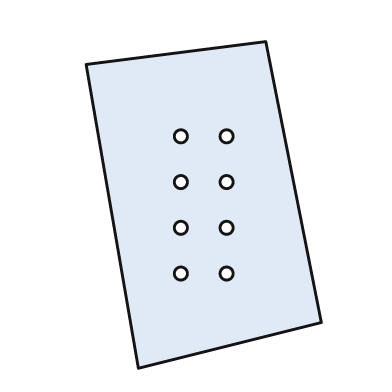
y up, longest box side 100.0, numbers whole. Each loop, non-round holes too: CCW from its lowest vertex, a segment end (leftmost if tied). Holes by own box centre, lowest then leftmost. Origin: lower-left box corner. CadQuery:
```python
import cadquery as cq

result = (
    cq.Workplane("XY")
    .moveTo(16.0, 0.0)
    .lineTo(72.0, 14.0)
    .lineTo(55.0, 100.0)
    .lineTo(0.0, 93.0)
    .close()
    .moveTo(29.0, 29.0)
    .circle(2.0)
    .moveTo(43.0, 29.0)
    .circle(2.0)
    .moveTo(29.0, 43.0)
    .circle(2.0)
    .moveTo(43.0, 43.0)
    .circle(2.0)
    .moveTo(29.0, 57.0)
    .circle(2.0)
    .moveTo(43.0, 57.0)
    .circle(2.0)
    .moveTo(29.0, 71.0)
    .circle(2.0)
    .moveTo(43.0, 71.0)
    .circle(2.0)
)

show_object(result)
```